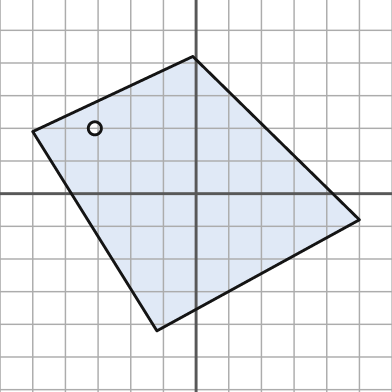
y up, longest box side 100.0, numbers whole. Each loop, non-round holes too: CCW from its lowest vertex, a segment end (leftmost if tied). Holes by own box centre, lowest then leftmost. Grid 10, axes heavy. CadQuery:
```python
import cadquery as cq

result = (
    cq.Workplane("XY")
    .moveTo(-12.0, -42.0)
    .lineTo(50.0, -8.0)
    .lineTo(-1.0, 42.0)
    .lineTo(-50.0, 19.0)
    .close()
    .moveTo(-31.0, 20.0)
    .circle(2.0)
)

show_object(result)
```